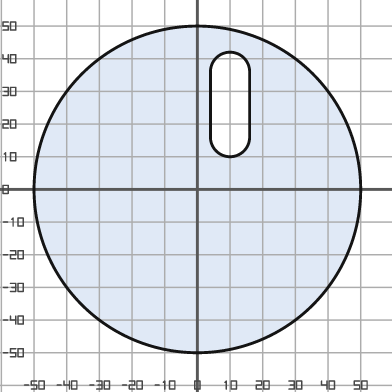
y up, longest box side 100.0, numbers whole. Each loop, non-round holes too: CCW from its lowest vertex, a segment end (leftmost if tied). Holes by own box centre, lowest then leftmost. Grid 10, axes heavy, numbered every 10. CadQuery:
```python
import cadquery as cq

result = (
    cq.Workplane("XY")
    .moveTo(0.0, 0.0)
    .circle(50.0)
    .moveTo(4.0, 16.0)
    .threePointArc((10.0, 10.0), (16.0, 16.0))
    .lineTo(16.0, 36.0)
    .threePointArc((10.0, 42.0), (4.0, 36.0))
    .close()
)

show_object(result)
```